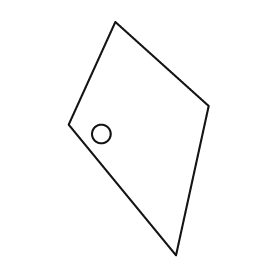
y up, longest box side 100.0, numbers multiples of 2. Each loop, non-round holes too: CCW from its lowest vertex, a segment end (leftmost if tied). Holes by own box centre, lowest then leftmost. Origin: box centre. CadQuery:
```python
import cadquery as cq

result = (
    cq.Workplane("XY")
    .moveTo(16.0, -50.0)
    .lineTo(30.0, 14.0)
    .lineTo(-10.0, 50.0)
    .lineTo(-30.0, 6.0)
    .close()
    .moveTo(-16.0, 2.0)
    .circle(4.0)
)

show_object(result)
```